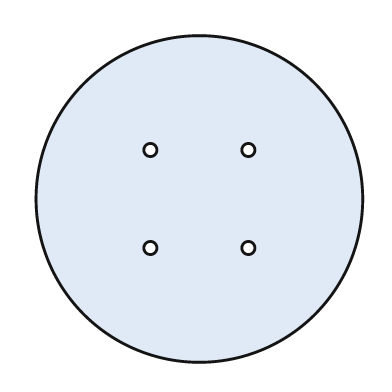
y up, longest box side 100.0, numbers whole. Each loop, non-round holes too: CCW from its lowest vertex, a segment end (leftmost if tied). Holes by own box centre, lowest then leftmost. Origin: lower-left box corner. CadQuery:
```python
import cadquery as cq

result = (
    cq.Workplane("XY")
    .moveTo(50.0, 50.0)
    .circle(50.0)
    .moveTo(35.0, 35.0)
    .circle(2.0)
    .moveTo(65.0, 35.0)
    .circle(2.0)
    .moveTo(35.0, 65.0)
    .circle(2.0)
    .moveTo(65.0, 65.0)
    .circle(2.0)
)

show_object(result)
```